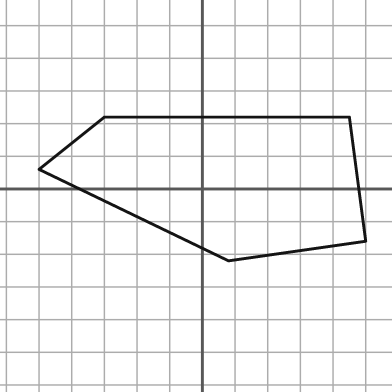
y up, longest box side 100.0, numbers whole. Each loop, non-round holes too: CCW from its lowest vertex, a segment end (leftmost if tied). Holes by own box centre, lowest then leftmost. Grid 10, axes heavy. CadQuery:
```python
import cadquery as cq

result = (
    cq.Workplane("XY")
    .moveTo(8.0, -22.0)
    .lineTo(50.0, -16.0)
    .lineTo(45.0, 22.0)
    .lineTo(-30.0, 22.0)
    .lineTo(-50.0, 6.0)
    .close()
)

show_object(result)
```